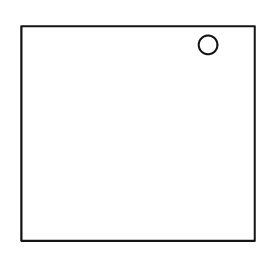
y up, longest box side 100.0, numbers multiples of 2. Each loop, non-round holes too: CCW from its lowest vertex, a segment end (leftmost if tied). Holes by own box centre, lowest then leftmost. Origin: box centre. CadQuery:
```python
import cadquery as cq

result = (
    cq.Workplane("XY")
    .moveTo(-50.0, -46.0)
    .lineTo(50.0, -46.0)
    .lineTo(50.0, 46.0)
    .lineTo(-50.0, 46.0)
    .close()
    .moveTo(30.0, 38.0)
    .circle(4.0)
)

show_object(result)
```